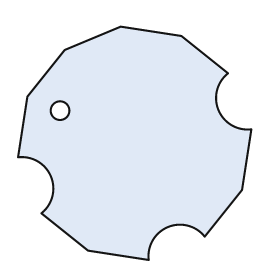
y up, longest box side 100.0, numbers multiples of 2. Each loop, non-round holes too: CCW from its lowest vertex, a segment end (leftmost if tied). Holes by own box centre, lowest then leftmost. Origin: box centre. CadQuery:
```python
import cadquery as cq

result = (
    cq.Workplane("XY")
    .moveTo(6.0, -50.0)
    .threePointArc((14.0, -36.0), (30.0, -40.0))
    .lineTo(46.0, -20.0)
    .lineTo(50.0, 6.0)
    .threePointArc((36.0, 14.0), (40.0, 30.0))
    .lineTo(20.0, 46.0)
    .lineTo(-6.0, 50.0)
    .lineTo(-30.0, 40.0)
    .lineTo(-46.0, 20.0)
    .lineTo(-50.0, -6.0)
    .threePointArc((-36.0, -14.0), (-40.0, -30.0))
    .lineTo(-20.0, -46.0)
    .close()
    .moveTo(-32.0, 14.0)
    .circle(4.0)
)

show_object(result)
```